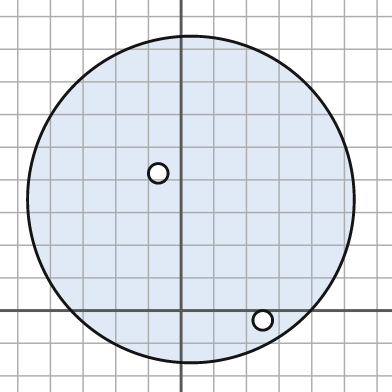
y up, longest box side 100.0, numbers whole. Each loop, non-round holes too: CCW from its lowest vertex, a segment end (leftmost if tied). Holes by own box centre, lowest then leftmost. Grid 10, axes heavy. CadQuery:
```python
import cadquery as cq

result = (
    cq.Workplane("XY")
    .moveTo(3.0, 34.0)
    .circle(50.0)
    .moveTo(25.0, -3.0)
    .circle(3.0)
    .moveTo(-7.0, 42.0)
    .circle(3.0)
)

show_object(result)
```